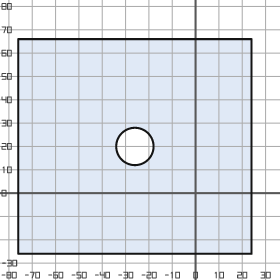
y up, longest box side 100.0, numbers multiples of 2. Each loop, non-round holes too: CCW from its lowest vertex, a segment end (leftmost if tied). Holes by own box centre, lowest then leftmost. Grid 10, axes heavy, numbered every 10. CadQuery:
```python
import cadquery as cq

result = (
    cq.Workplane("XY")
    .moveTo(-76.0, -26.0)
    .lineTo(24.0, -26.0)
    .lineTo(24.0, 66.0)
    .lineTo(-76.0, 66.0)
    .close()
    .moveTo(-26.0, 20.0)
    .circle(8.0)
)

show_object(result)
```